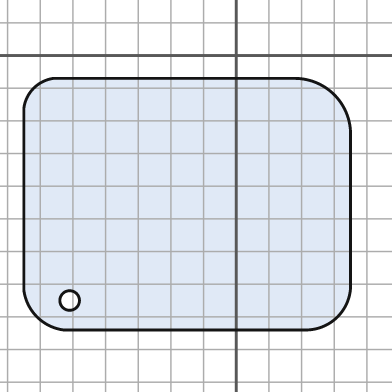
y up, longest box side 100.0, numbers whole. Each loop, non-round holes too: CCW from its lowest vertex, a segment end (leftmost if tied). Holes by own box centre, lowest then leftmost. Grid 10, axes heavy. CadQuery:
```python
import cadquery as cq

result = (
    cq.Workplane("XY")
    .moveTo(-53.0, -84.0)
    .lineTo(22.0, -84.0)
    .threePointArc((31.0, -80.0), (35.0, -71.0))
    .lineTo(35.0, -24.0)
    .threePointArc((30.0, -12.0), (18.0, -7.0))
    .lineTo(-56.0, -7.0)
    .threePointArc((-62.0, -10.0), (-65.0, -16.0))
    .lineTo(-65.0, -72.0)
    .threePointArc((-61.0, -80.0), (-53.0, -84.0))
    .close()
    .moveTo(-51.0, -75.0)
    .circle(3.0)
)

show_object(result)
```